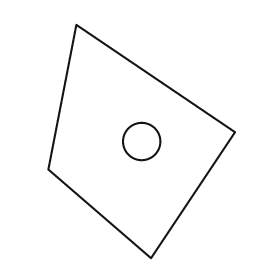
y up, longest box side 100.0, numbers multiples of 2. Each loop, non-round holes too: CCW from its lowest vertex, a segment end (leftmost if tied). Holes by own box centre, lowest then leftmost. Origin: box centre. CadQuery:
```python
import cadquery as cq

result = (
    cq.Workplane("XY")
    .moveTo(4.0, -50.0)
    .lineTo(40.0, 4.0)
    .lineTo(-28.0, 50.0)
    .lineTo(-40.0, -12.0)
    .close()
    .moveTo(0.0, 0.0)
    .circle(8.0)
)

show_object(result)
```